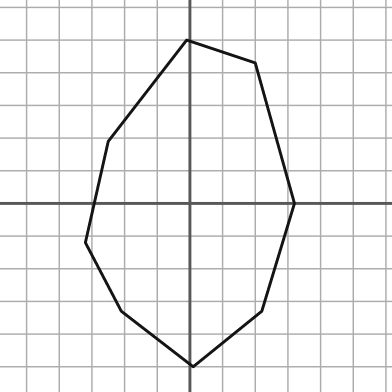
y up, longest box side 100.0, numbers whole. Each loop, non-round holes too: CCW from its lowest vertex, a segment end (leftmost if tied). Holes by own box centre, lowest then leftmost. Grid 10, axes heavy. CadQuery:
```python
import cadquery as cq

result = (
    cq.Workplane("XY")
    .moveTo(1.0, -50.0)
    .lineTo(22.0, -33.0)
    .lineTo(32.0, 0.0)
    .lineTo(20.0, 43.0)
    .lineTo(-1.0, 50.0)
    .lineTo(-25.0, 19.0)
    .lineTo(-32.0, -12.0)
    .lineTo(-21.0, -33.0)
    .close()
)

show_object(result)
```